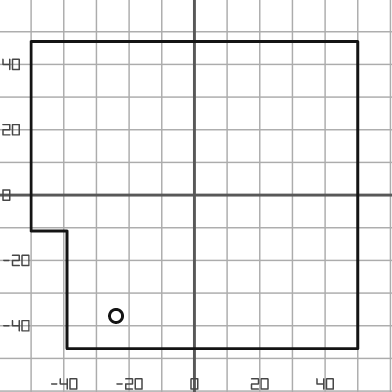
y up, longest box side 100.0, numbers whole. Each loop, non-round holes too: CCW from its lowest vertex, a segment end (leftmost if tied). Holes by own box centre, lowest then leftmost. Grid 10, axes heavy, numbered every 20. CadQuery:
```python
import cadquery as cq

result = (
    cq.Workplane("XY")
    .moveTo(-39.0, -47.0)
    .lineTo(50.0, -47.0)
    .lineTo(50.0, 47.0)
    .lineTo(-50.0, 47.0)
    .lineTo(-50.0, -11.0)
    .lineTo(-39.0, -11.0)
    .close()
    .moveTo(-24.0, -37.0)
    .circle(2.0)
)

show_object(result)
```